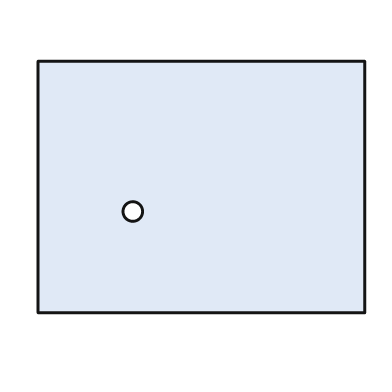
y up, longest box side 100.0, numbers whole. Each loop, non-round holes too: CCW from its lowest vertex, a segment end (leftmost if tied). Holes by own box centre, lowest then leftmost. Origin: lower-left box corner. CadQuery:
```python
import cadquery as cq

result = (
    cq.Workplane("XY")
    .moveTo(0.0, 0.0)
    .lineTo(100.0, 0.0)
    .lineTo(100.0, 77.0)
    .lineTo(0.0, 77.0)
    .close()
    .moveTo(29.0, 31.0)
    .circle(3.0)
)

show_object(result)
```